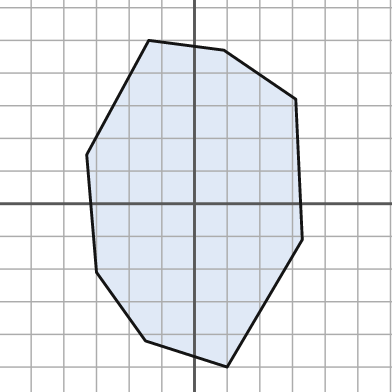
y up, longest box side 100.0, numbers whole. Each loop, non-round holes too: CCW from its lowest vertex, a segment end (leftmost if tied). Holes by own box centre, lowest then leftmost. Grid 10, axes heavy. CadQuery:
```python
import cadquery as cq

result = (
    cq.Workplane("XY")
    .moveTo(10.0, -50.0)
    .lineTo(33.0, -11.0)
    .lineTo(31.0, 32.0)
    .lineTo(9.0, 47.0)
    .lineTo(-14.0, 50.0)
    .lineTo(-33.0, 15.0)
    .lineTo(-30.0, -21.0)
    .lineTo(-15.0, -42.0)
    .close()
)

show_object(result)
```